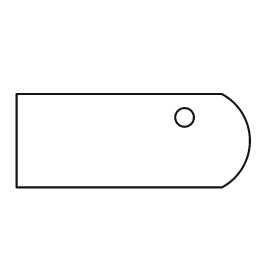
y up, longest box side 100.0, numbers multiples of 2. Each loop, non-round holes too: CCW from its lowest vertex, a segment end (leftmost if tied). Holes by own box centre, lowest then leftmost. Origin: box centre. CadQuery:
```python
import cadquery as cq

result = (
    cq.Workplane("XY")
    .moveTo(-50.0, -20.0)
    .lineTo(38.0, -20.0)
    .threePointArc((50.0, 0.0), (38.0, 20.0))
    .lineTo(-50.0, 20.0)
    .close()
    .moveTo(22.0, 10.0)
    .circle(4.0)
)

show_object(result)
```